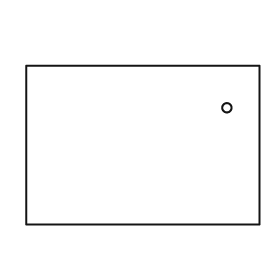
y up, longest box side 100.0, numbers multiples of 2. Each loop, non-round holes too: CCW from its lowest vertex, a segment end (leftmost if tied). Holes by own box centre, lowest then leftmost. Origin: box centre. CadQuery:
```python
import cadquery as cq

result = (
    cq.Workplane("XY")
    .moveTo(-50.0, -34.0)
    .lineTo(50.0, -34.0)
    .lineTo(50.0, 34.0)
    .lineTo(-50.0, 34.0)
    .close()
    .moveTo(36.0, 16.0)
    .circle(2.0)
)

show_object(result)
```